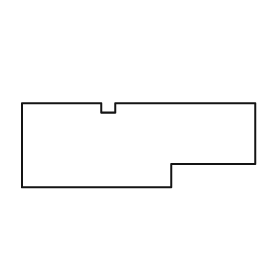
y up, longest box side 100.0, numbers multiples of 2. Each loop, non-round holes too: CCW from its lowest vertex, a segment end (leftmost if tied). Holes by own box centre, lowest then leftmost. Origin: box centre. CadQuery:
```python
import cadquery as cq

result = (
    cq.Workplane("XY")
    .moveTo(-50.0, -18.0)
    .lineTo(14.0, -18.0)
    .lineTo(14.0, -8.0)
    .lineTo(50.0, -8.0)
    .lineTo(50.0, 18.0)
    .lineTo(-10.0, 18.0)
    .lineTo(-10.0, 14.0)
    .lineTo(-16.0, 14.0)
    .lineTo(-16.0, 18.0)
    .lineTo(-50.0, 18.0)
    .close()
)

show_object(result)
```